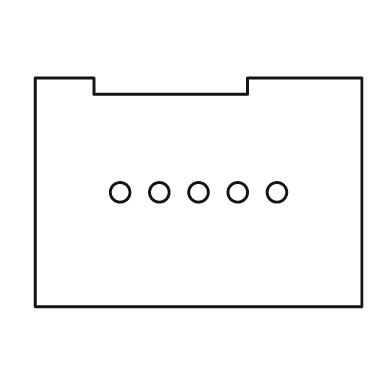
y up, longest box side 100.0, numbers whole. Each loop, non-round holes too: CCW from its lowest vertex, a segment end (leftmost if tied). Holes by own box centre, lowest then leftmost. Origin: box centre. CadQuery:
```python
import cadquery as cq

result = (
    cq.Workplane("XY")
    .moveTo(-50.0, -35.0)
    .lineTo(50.0, -35.0)
    .lineTo(50.0, 35.0)
    .lineTo(15.0, 35.0)
    .lineTo(15.0, 30.0)
    .lineTo(-32.0, 30.0)
    .lineTo(-32.0, 35.0)
    .lineTo(-50.0, 35.0)
    .close()
    .moveTo(-24.0, 0.0)
    .circle(3.0)
    .moveTo(-12.0, 0.0)
    .circle(3.0)
    .moveTo(0.0, 0.0)
    .circle(3.0)
    .moveTo(12.0, 0.0)
    .circle(3.0)
    .moveTo(24.0, 0.0)
    .circle(3.0)
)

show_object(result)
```